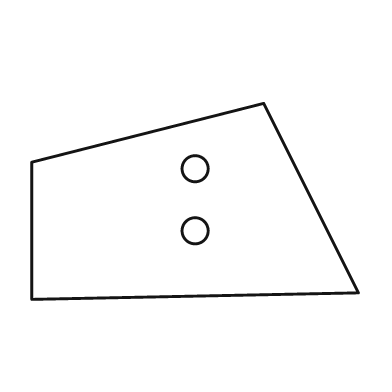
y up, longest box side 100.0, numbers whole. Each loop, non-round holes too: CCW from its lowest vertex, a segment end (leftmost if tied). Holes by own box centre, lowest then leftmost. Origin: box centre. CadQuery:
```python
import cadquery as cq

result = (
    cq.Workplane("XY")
    .moveTo(-50.0, -30.0)
    .lineTo(50.0, -28.0)
    .lineTo(21.0, 30.0)
    .lineTo(-50.0, 12.0)
    .close()
    .moveTo(0.0, -9.0)
    .circle(4.0)
    .moveTo(0.0, 10.0)
    .circle(4.0)
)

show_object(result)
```